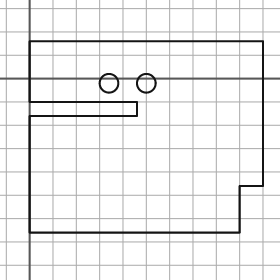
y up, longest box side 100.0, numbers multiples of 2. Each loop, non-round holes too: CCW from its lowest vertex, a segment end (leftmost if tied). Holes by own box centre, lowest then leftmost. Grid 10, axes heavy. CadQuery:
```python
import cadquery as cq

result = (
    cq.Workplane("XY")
    .moveTo(0.0, -66.0)
    .lineTo(90.0, -66.0)
    .lineTo(90.0, -46.0)
    .lineTo(100.0, -46.0)
    .lineTo(100.0, 16.0)
    .lineTo(0.0, 16.0)
    .lineTo(0.0, -10.0)
    .lineTo(46.0, -10.0)
    .lineTo(46.0, -16.0)
    .lineTo(0.0, -16.0)
    .close()
    .moveTo(34.0, -2.0)
    .circle(4.0)
    .moveTo(50.0, -2.0)
    .circle(4.0)
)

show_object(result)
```